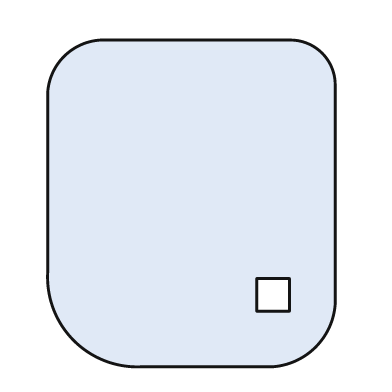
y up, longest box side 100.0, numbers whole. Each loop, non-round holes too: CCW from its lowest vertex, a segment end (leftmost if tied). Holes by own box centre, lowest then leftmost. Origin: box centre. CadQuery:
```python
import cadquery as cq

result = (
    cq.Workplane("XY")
    .moveTo(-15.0, -50.0)
    .lineTo(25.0, -50.0)
    .threePointArc((38.0, -44.0), (44.0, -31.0))
    .lineTo(44.0, 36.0)
    .threePointArc((40.0, 46.0), (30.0, 50.0))
    .lineTo(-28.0, 50.0)
    .threePointArc((-39.0, 45.0), (-44.0, 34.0))
    .lineTo(-44.0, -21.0)
    .threePointArc((-36.0, -42.0), (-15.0, -50.0))
    .close()
    .moveTo(20.0, -33.0)
    .lineTo(30.0, -33.0)
    .lineTo(30.0, -23.0)
    .lineTo(20.0, -23.0)
    .close()
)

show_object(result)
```